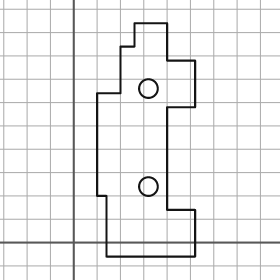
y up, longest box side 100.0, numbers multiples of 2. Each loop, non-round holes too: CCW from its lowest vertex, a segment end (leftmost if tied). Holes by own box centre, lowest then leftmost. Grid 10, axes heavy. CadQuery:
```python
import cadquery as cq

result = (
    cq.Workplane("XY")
    .moveTo(14.0, -6.0)
    .lineTo(52.0, -6.0)
    .lineTo(52.0, 14.0)
    .lineTo(40.0, 14.0)
    .lineTo(40.0, 58.0)
    .lineTo(52.0, 58.0)
    .lineTo(52.0, 78.0)
    .lineTo(40.0, 78.0)
    .lineTo(40.0, 94.0)
    .lineTo(26.0, 94.0)
    .lineTo(26.0, 84.0)
    .lineTo(20.0, 84.0)
    .lineTo(20.0, 64.0)
    .lineTo(10.0, 64.0)
    .lineTo(10.0, 20.0)
    .lineTo(14.0, 20.0)
    .close()
    .moveTo(32.0, 24.0)
    .circle(4.0)
    .moveTo(32.0, 66.0)
    .circle(4.0)
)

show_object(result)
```